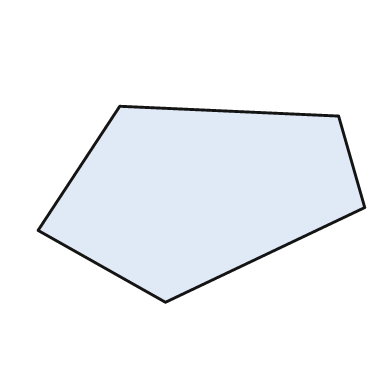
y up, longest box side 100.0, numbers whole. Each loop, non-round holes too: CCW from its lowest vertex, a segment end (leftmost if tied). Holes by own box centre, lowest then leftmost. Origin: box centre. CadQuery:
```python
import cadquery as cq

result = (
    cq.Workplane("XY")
    .moveTo(-11.0, -30.0)
    .lineTo(50.0, -1.0)
    .lineTo(42.0, 27.0)
    .lineTo(-25.0, 30.0)
    .lineTo(-50.0, -8.0)
    .close()
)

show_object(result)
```